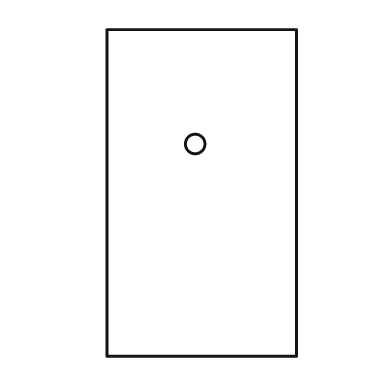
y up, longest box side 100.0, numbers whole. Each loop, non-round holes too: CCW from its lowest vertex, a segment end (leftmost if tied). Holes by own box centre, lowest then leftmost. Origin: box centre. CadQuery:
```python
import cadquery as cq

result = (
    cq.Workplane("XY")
    .moveTo(-29.0, -50.0)
    .lineTo(29.0, -50.0)
    .lineTo(29.0, 50.0)
    .lineTo(-29.0, 50.0)
    .close()
    .moveTo(-2.0, 15.0)
    .circle(3.0)
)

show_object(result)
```